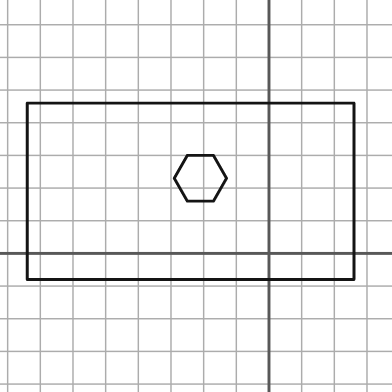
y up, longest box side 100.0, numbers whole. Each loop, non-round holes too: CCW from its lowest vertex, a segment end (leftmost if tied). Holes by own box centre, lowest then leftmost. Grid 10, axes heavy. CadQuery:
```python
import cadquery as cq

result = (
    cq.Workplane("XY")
    .moveTo(-74.0, -8.0)
    .lineTo(26.0, -8.0)
    .lineTo(26.0, 46.0)
    .lineTo(-74.0, 46.0)
    .close()
    .moveTo(-25.0, 16.0)
    .lineTo(-17.0, 16.0)
    .lineTo(-13.0, 23.0)
    .lineTo(-17.0, 30.0)
    .lineTo(-25.0, 30.0)
    .lineTo(-29.0, 23.0)
    .close()
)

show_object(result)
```